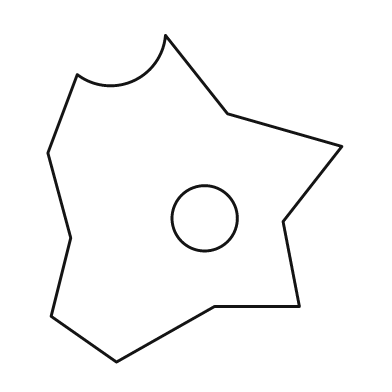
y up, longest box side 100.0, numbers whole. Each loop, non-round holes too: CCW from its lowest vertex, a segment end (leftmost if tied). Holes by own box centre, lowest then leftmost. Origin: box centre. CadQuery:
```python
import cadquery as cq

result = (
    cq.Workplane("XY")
    .moveTo(-24.0, -50.0)
    .lineTo(6.0, -33.0)
    .lineTo(32.0, -33.0)
    .lineTo(27.0, -7.0)
    .lineTo(45.0, 16.0)
    .lineTo(10.0, 26.0)
    .lineTo(-9.0, 50.0)
    .threePointArc((-19.0, 36.0), (-36.0, 38.0))
    .lineTo(-45.0, 14.0)
    .lineTo(-38.0, -12.0)
    .lineTo(-44.0, -36.0)
    .close()
    .moveTo(3.0, -6.0)
    .circle(10.0)
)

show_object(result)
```